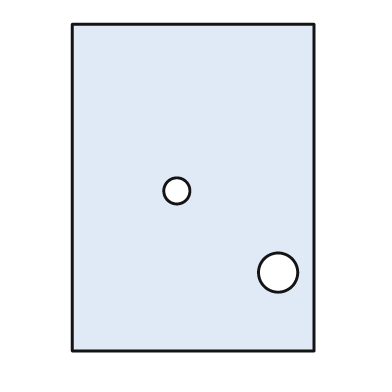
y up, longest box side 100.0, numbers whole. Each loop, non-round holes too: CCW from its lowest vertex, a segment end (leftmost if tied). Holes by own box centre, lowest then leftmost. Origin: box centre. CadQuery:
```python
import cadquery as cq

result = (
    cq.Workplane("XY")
    .moveTo(-37.0, -50.0)
    .lineTo(37.0, -50.0)
    .lineTo(37.0, 50.0)
    .lineTo(-37.0, 50.0)
    .close()
    .moveTo(26.0, -26.0)
    .circle(6.0)
    .moveTo(-5.0, -1.0)
    .circle(4.0)
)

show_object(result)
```